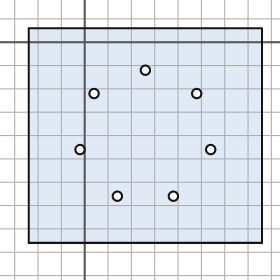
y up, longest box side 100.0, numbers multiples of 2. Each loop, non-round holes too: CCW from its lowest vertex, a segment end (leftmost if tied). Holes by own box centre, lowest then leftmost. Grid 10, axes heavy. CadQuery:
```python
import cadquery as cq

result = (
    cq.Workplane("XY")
    .moveTo(-24.0, -86.0)
    .lineTo(76.0, -86.0)
    .lineTo(76.0, 6.0)
    .lineTo(-24.0, 6.0)
    .close()
    .moveTo(14.0, -66.0)
    .circle(2.0)
    .moveTo(38.0, -66.0)
    .circle(2.0)
    .moveTo(-2.0, -46.0)
    .circle(2.0)
    .moveTo(54.0, -46.0)
    .circle(2.0)
    .moveTo(4.0, -22.0)
    .circle(2.0)
    .moveTo(48.0, -22.0)
    .circle(2.0)
    .moveTo(26.0, -12.0)
    .circle(2.0)
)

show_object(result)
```